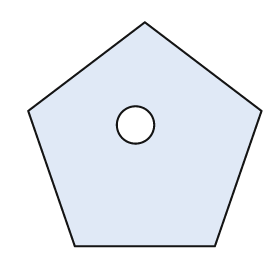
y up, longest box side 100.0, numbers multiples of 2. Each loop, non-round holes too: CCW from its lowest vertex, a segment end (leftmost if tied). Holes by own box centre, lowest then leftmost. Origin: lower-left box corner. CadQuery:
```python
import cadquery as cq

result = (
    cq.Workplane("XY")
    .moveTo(20.0, 0.0)
    .lineTo(80.0, 0.0)
    .lineTo(100.0, 58.0)
    .lineTo(50.0, 96.0)
    .lineTo(0.0, 58.0)
    .close()
    .moveTo(46.0, 52.0)
    .circle(8.0)
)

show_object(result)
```